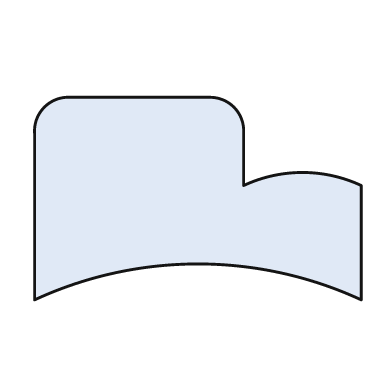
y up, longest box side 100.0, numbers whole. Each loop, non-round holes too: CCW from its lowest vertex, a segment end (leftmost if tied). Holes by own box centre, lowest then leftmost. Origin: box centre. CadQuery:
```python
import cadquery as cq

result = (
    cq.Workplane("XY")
    .moveTo(-50.0, -31.0)
    .threePointArc((0.0, -20.0), (50.0, -31.0))
    .lineTo(50.0, 4.0)
    .threePointArc((32.0, 8.0), (14.0, 4.0))
    .lineTo(14.0, 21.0)
    .threePointArc((11.0, 28.0), (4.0, 31.0))
    .lineTo(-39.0, 31.0)
    .threePointArc((-47.0, 28.0), (-50.0, 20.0))
    .close()
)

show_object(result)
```